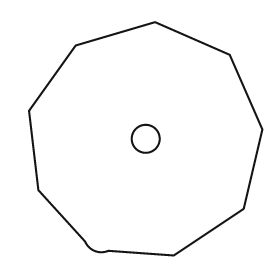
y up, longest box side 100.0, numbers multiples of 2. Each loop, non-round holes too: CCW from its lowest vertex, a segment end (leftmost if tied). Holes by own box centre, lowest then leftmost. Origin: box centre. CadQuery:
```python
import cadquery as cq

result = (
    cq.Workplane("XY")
    .moveTo(12.0, -50.0)
    .lineTo(42.0, -30.0)
    .lineTo(50.0, 4.0)
    .lineTo(36.0, 36.0)
    .lineTo(4.0, 50.0)
    .lineTo(-30.0, 40.0)
    .lineTo(-50.0, 12.0)
    .lineTo(-46.0, -22.0)
    .lineTo(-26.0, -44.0)
    .threePointArc((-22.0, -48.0), (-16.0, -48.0))
    .close()
    .moveTo(0.0, 0.0)
    .circle(6.0)
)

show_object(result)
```